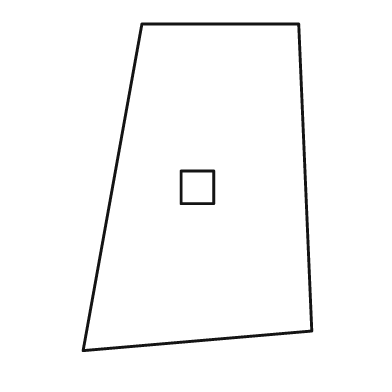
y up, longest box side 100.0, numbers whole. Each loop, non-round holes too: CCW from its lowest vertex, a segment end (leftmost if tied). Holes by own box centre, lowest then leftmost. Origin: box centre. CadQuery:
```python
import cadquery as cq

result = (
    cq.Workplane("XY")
    .moveTo(-35.0, -50.0)
    .lineTo(35.0, -44.0)
    .lineTo(31.0, 50.0)
    .lineTo(-17.0, 50.0)
    .close()
    .moveTo(-5.0, -5.0)
    .lineTo(5.0, -5.0)
    .lineTo(5.0, 5.0)
    .lineTo(-5.0, 5.0)
    .close()
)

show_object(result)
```